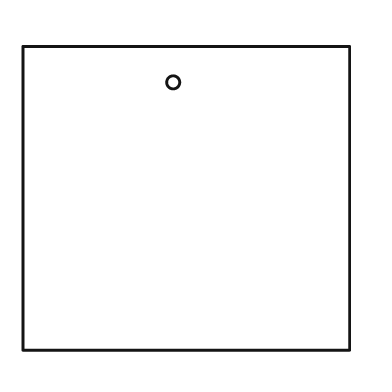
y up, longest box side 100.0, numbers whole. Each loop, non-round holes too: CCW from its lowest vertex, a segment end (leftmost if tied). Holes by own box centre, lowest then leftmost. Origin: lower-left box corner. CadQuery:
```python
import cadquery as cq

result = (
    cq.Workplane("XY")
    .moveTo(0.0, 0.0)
    .lineTo(100.0, 0.0)
    .lineTo(100.0, 93.0)
    .lineTo(0.0, 93.0)
    .close()
    .moveTo(46.0, 82.0)
    .circle(2.0)
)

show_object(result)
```